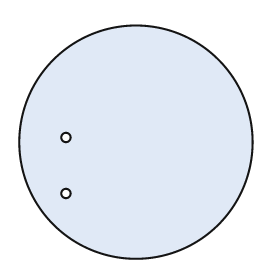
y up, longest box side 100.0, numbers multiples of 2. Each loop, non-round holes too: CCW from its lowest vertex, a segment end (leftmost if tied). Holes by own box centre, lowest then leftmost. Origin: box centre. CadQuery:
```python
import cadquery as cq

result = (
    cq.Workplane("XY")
    .moveTo(0.0, 0.0)
    .circle(50.0)
    .moveTo(-30.0, -22.0)
    .circle(2.0)
    .moveTo(-30.0, 2.0)
    .circle(2.0)
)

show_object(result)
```